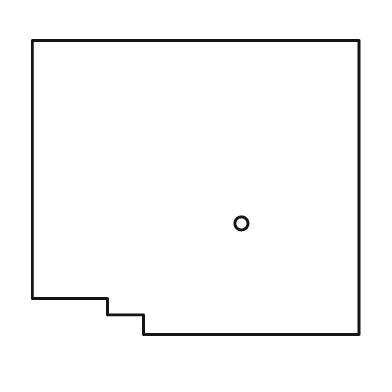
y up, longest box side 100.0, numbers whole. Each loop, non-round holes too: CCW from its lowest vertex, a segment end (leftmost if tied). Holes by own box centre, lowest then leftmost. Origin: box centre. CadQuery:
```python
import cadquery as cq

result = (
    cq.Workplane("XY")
    .moveTo(-16.0, -45.0)
    .lineTo(50.0, -45.0)
    .lineTo(50.0, 45.0)
    .lineTo(-50.0, 45.0)
    .lineTo(-50.0, -34.0)
    .lineTo(-27.0, -34.0)
    .lineTo(-27.0, -39.0)
    .lineTo(-16.0, -39.0)
    .close()
    .moveTo(14.0, -11.0)
    .circle(2.0)
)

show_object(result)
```